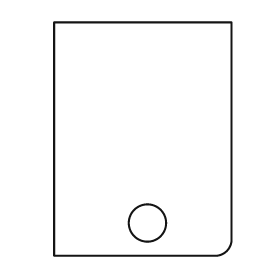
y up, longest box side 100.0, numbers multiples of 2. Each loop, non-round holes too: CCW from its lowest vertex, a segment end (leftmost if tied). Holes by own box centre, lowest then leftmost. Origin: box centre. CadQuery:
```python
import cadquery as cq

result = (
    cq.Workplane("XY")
    .moveTo(-38.0, -50.0)
    .lineTo(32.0, -50.0)
    .threePointArc((36.0, -48.0), (38.0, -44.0))
    .lineTo(38.0, 50.0)
    .lineTo(-38.0, 50.0)
    .close()
    .moveTo(2.0, -36.0)
    .circle(8.0)
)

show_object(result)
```